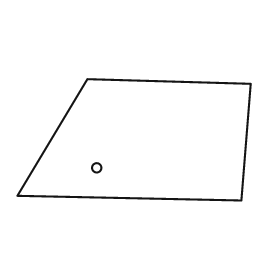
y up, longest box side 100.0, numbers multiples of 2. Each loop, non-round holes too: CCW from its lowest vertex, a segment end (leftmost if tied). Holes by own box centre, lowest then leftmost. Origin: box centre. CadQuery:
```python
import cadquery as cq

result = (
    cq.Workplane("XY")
    .moveTo(46.0, -26.0)
    .lineTo(50.0, 24.0)
    .lineTo(-20.0, 26.0)
    .lineTo(-50.0, -24.0)
    .close()
    .moveTo(-16.0, -12.0)
    .circle(2.0)
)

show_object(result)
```